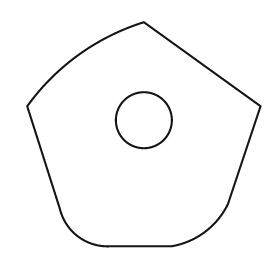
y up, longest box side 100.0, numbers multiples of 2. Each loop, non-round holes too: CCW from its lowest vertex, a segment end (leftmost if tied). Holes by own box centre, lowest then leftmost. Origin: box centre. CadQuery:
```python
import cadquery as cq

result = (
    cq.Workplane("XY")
    .moveTo(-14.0, -48.0)
    .lineTo(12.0, -48.0)
    .threePointArc((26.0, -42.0), (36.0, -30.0))
    .lineTo(50.0, 12.0)
    .lineTo(0.0, 48.0)
    .threePointArc((-28.0, 34.0), (-50.0, 12.0))
    .lineTo(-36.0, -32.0)
    .threePointArc((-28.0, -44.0), (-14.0, -48.0))
    .close()
    .moveTo(0.0, 6.0)
    .circle(12.0)
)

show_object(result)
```